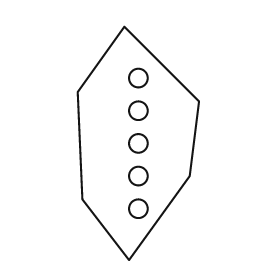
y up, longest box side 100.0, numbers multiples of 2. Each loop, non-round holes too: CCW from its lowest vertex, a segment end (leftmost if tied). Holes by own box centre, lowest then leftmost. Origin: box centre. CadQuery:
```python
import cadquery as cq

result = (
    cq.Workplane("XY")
    .moveTo(-4.0, -50.0)
    .lineTo(22.0, -14.0)
    .lineTo(26.0, 18.0)
    .lineTo(-6.0, 50.0)
    .lineTo(-26.0, 22.0)
    .lineTo(-24.0, -24.0)
    .close()
    .moveTo(0.0, -28.0)
    .circle(4.0)
    .moveTo(0.0, -14.0)
    .circle(4.0)
    .moveTo(0.0, 0.0)
    .circle(4.0)
    .moveTo(0.0, 14.0)
    .circle(4.0)
    .moveTo(0.0, 28.0)
    .circle(4.0)
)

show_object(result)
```